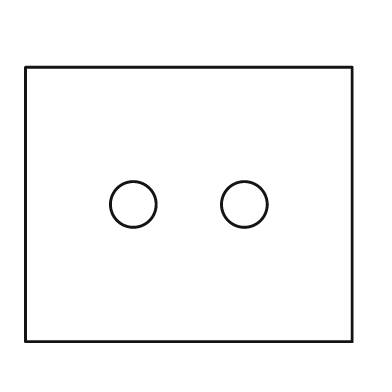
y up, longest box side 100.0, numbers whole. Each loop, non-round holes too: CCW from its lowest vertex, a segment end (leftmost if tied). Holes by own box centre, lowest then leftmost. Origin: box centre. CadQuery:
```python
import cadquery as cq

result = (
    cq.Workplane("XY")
    .moveTo(-50.0, -42.0)
    .lineTo(50.0, -42.0)
    .lineTo(50.0, 42.0)
    .lineTo(-50.0, 42.0)
    .close()
    .moveTo(-17.0, 0.0)
    .circle(7.0)
    .moveTo(17.0, 0.0)
    .circle(7.0)
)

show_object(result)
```